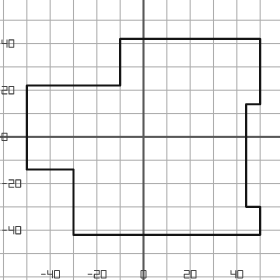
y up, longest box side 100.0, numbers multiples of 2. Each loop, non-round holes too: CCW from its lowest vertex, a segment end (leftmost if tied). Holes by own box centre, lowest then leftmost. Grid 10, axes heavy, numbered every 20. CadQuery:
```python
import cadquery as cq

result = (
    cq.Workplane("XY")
    .moveTo(-30.0, -42.0)
    .lineTo(50.0, -42.0)
    .lineTo(50.0, -30.0)
    .lineTo(44.0, -30.0)
    .lineTo(44.0, 14.0)
    .lineTo(50.0, 14.0)
    .lineTo(50.0, 42.0)
    .lineTo(-10.0, 42.0)
    .lineTo(-10.0, 22.0)
    .lineTo(-50.0, 22.0)
    .lineTo(-50.0, -14.0)
    .lineTo(-30.0, -14.0)
    .close()
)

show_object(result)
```